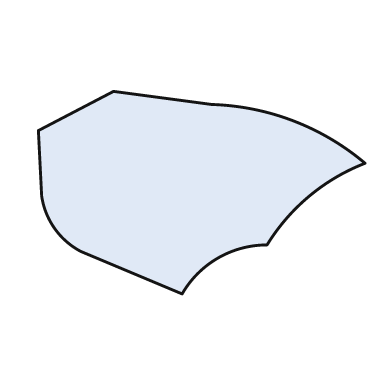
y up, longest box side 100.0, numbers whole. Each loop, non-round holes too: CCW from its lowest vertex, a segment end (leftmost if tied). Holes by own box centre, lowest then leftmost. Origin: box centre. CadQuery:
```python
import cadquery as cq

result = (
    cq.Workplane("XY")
    .moveTo(-6.0, -31.0)
    .threePointArc((5.0, -20.0), (20.0, -16.0))
    .threePointArc((33.0, -1.0), (50.0, 9.0))
    .threePointArc((28.0, 22.0), (3.0, 27.0))
    .lineTo(-27.0, 31.0)
    .lineTo(-50.0, 19.0)
    .lineTo(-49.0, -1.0)
    .threePointArc((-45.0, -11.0), (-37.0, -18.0))
    .close()
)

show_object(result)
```